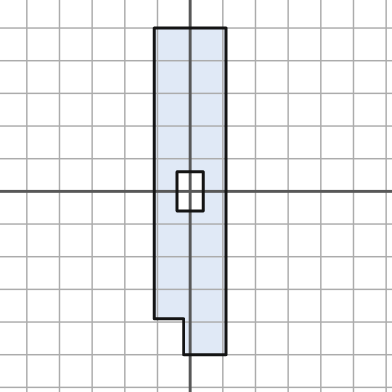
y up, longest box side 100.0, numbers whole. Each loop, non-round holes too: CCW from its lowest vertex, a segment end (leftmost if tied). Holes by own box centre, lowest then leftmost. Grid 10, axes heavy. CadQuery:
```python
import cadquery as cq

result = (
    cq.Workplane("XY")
    .moveTo(-2.0, -50.0)
    .lineTo(11.0, -50.0)
    .lineTo(11.0, 50.0)
    .lineTo(-11.0, 50.0)
    .lineTo(-11.0, -39.0)
    .lineTo(-2.0, -39.0)
    .close()
    .moveTo(-4.0, -6.0)
    .lineTo(4.0, -6.0)
    .lineTo(4.0, 6.0)
    .lineTo(-4.0, 6.0)
    .close()
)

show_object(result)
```